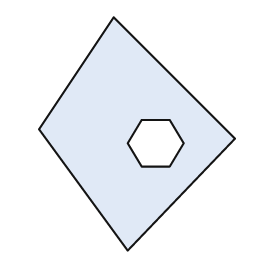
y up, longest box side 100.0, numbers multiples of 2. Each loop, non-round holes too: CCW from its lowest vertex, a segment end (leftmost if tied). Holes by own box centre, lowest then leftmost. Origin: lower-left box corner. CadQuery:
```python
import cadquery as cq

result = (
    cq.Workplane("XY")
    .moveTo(38.0, 0.0)
    .lineTo(84.0, 48.0)
    .lineTo(32.0, 100.0)
    .lineTo(0.0, 52.0)
    .close()
    .moveTo(44.0, 36.0)
    .lineTo(56.0, 36.0)
    .lineTo(62.0, 46.0)
    .lineTo(56.0, 56.0)
    .lineTo(44.0, 56.0)
    .lineTo(38.0, 46.0)
    .close()
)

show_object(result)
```